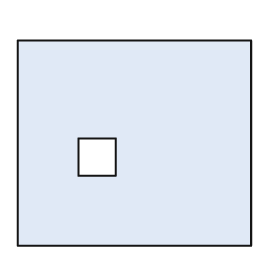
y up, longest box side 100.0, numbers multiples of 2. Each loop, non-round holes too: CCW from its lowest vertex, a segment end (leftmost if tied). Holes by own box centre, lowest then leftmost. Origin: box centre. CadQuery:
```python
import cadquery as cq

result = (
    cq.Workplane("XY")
    .moveTo(-50.0, -44.0)
    .lineTo(50.0, -44.0)
    .lineTo(50.0, 44.0)
    .lineTo(-50.0, 44.0)
    .close()
    .moveTo(-24.0, -14.0)
    .lineTo(-8.0, -14.0)
    .lineTo(-8.0, 2.0)
    .lineTo(-24.0, 2.0)
    .close()
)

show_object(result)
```